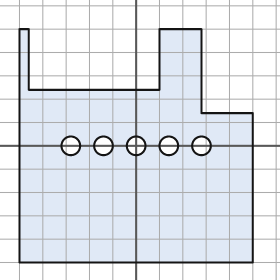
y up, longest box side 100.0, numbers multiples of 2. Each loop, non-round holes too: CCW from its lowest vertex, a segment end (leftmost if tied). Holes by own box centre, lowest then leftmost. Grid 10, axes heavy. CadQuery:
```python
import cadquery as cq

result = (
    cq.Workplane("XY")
    .moveTo(-50.0, -50.0)
    .lineTo(50.0, -50.0)
    .lineTo(50.0, 14.0)
    .lineTo(28.0, 14.0)
    .lineTo(28.0, 50.0)
    .lineTo(10.0, 50.0)
    .lineTo(10.0, 24.0)
    .lineTo(-46.0, 24.0)
    .lineTo(-46.0, 50.0)
    .lineTo(-50.0, 50.0)
    .close()
    .moveTo(-28.0, 0.0)
    .circle(4.0)
    .moveTo(-14.0, 0.0)
    .circle(4.0)
    .moveTo(0.0, 0.0)
    .circle(4.0)
    .moveTo(14.0, 0.0)
    .circle(4.0)
    .moveTo(28.0, 0.0)
    .circle(4.0)
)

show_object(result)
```